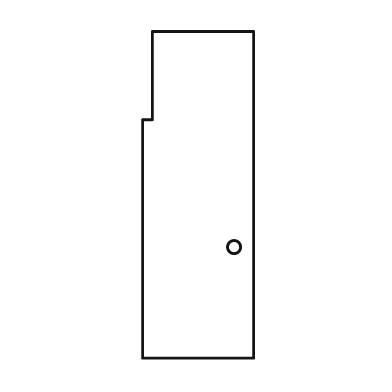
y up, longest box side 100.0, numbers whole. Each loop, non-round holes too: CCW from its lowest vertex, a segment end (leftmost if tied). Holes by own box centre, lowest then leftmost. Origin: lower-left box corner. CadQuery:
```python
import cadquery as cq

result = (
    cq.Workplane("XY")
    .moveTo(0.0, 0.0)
    .lineTo(34.0, 0.0)
    .lineTo(34.0, 100.0)
    .lineTo(3.0, 100.0)
    .lineTo(3.0, 73.0)
    .lineTo(0.0, 73.0)
    .close()
    .moveTo(28.0, 34.0)
    .circle(2.0)
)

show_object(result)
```